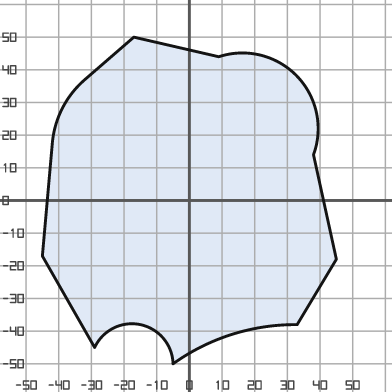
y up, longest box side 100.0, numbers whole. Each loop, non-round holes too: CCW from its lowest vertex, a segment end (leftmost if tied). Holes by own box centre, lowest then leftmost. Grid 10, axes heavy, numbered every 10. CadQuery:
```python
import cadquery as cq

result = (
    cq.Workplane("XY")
    .moveTo(-5.0, -50.0)
    .threePointArc((13.0, -41.0), (33.0, -38.0))
    .lineTo(45.0, -18.0)
    .lineTo(38.0, 14.0)
    .threePointArc((33.0, 38.0), (9.0, 44.0))
    .lineTo(-17.0, 50.0)
    .lineTo(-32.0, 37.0)
    .threePointArc((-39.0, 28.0), (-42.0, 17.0))
    .lineTo(-45.0, -17.0)
    .lineTo(-29.0, -45.0)
    .threePointArc((-15.0, -38.0), (-5.0, -50.0))
    .close()
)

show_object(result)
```